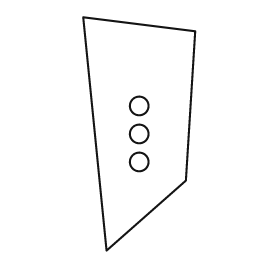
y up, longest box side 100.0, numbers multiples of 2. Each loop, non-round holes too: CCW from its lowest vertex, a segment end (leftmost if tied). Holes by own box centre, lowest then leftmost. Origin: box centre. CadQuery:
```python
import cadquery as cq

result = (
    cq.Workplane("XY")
    .moveTo(-14.0, -50.0)
    .lineTo(20.0, -20.0)
    .lineTo(24.0, 44.0)
    .lineTo(-24.0, 50.0)
    .close()
    .moveTo(0.0, -12.0)
    .circle(4.0)
    .moveTo(0.0, 0.0)
    .circle(4.0)
    .moveTo(0.0, 12.0)
    .circle(4.0)
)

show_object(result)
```